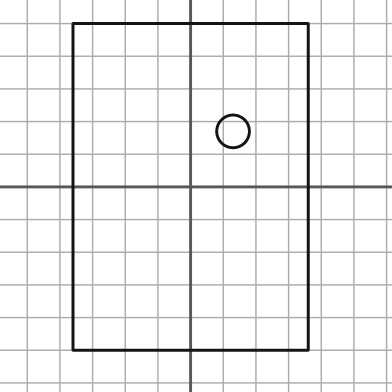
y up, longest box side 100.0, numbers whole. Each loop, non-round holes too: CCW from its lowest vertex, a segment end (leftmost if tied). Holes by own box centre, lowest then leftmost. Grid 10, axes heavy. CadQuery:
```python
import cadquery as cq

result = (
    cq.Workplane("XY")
    .moveTo(-36.0, -50.0)
    .lineTo(36.0, -50.0)
    .lineTo(36.0, 50.0)
    .lineTo(-36.0, 50.0)
    .close()
    .moveTo(13.0, 17.0)
    .circle(5.0)
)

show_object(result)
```